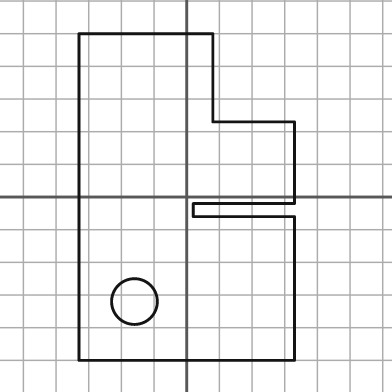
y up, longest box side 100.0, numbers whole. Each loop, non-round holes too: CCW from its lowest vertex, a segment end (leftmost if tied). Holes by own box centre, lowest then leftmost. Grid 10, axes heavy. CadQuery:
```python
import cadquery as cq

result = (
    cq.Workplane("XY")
    .moveTo(-33.0, -50.0)
    .lineTo(33.0, -50.0)
    .lineTo(33.0, -6.0)
    .lineTo(2.0, -6.0)
    .lineTo(2.0, -2.0)
    .lineTo(33.0, -2.0)
    .lineTo(33.0, 23.0)
    .lineTo(8.0, 23.0)
    .lineTo(8.0, 50.0)
    .lineTo(-33.0, 50.0)
    .close()
    .moveTo(-16.0, -32.0)
    .circle(7.0)
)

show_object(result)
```